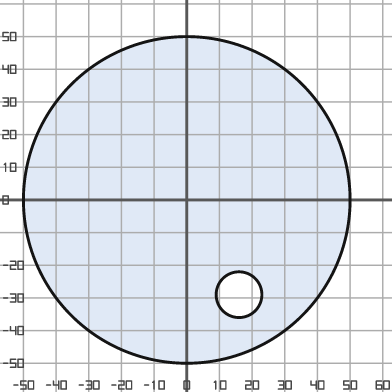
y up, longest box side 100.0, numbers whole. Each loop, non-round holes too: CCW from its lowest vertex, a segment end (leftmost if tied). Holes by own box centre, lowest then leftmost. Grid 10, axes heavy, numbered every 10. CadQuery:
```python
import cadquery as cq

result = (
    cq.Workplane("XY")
    .moveTo(0.0, 0.0)
    .circle(50.0)
    .moveTo(16.0, -29.0)
    .circle(7.0)
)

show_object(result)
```